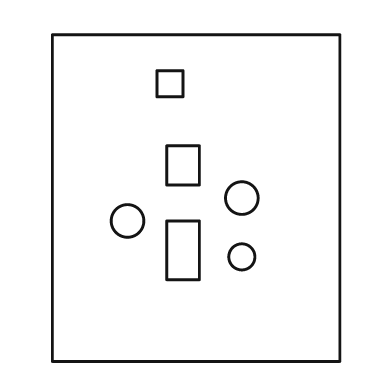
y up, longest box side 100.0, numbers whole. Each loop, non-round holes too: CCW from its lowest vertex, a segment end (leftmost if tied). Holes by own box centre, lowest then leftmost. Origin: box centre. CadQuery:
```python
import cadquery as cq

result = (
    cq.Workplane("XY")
    .moveTo(-44.0, -50.0)
    .lineTo(44.0, -50.0)
    .lineTo(44.0, 50.0)
    .lineTo(-44.0, 50.0)
    .close()
    .moveTo(14.0, -18.0)
    .circle(4.0)
    .moveTo(-9.0, -25.0)
    .lineTo(1.0, -25.0)
    .lineTo(1.0, -7.0)
    .lineTo(-9.0, -7.0)
    .close()
    .moveTo(-21.0, -7.0)
    .circle(5.0)
    .moveTo(14.0, 0.0)
    .circle(5.0)
    .moveTo(-9.0, 4.0)
    .lineTo(1.0, 4.0)
    .lineTo(1.0, 16.0)
    .lineTo(-9.0, 16.0)
    .close()
    .moveTo(-12.0, 31.0)
    .lineTo(-4.0, 31.0)
    .lineTo(-4.0, 39.0)
    .lineTo(-12.0, 39.0)
    .close()
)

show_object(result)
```